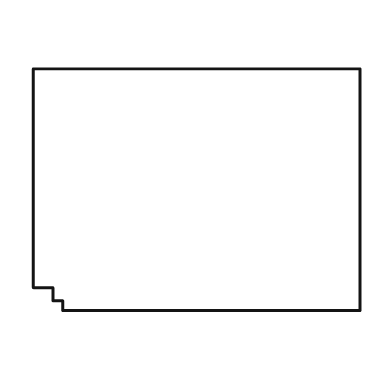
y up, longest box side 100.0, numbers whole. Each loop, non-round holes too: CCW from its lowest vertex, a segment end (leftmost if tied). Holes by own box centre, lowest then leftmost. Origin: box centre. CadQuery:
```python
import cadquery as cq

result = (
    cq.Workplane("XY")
    .moveTo(-41.0, -37.0)
    .lineTo(50.0, -37.0)
    .lineTo(50.0, 37.0)
    .lineTo(-50.0, 37.0)
    .lineTo(-50.0, -30.0)
    .lineTo(-44.0, -30.0)
    .lineTo(-44.0, -34.0)
    .lineTo(-41.0, -34.0)
    .close()
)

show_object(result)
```